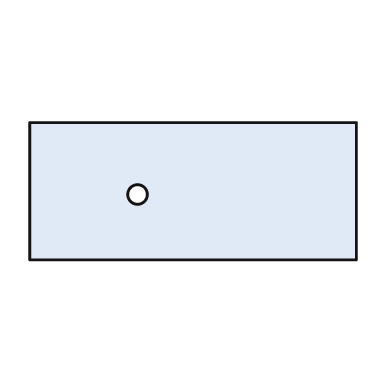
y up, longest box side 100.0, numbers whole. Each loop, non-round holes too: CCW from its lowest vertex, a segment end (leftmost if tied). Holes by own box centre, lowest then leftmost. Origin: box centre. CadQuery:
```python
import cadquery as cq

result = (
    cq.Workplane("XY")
    .moveTo(-50.0, -21.0)
    .lineTo(50.0, -21.0)
    .lineTo(50.0, 21.0)
    .lineTo(-50.0, 21.0)
    .close()
    .moveTo(-17.0, -1.0)
    .circle(3.0)
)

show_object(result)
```